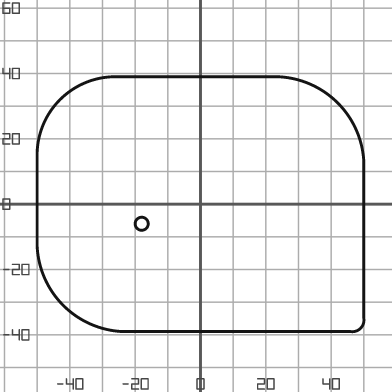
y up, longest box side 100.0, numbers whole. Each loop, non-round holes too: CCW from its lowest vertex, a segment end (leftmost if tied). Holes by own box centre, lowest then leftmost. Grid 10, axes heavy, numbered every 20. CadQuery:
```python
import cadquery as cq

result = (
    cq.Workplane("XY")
    .moveTo(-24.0, -39.0)
    .lineTo(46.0, -39.0)
    .threePointArc((49.0, -38.0), (50.0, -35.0))
    .lineTo(50.0, 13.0)
    .threePointArc((42.0, 31.0), (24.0, 39.0))
    .lineTo(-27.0, 39.0)
    .threePointArc((-43.0, 32.0), (-50.0, 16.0))
    .lineTo(-50.0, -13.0)
    .threePointArc((-42.0, -31.0), (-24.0, -39.0))
    .close()
    .moveTo(-18.0, -6.0)
    .circle(2.0)
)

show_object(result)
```